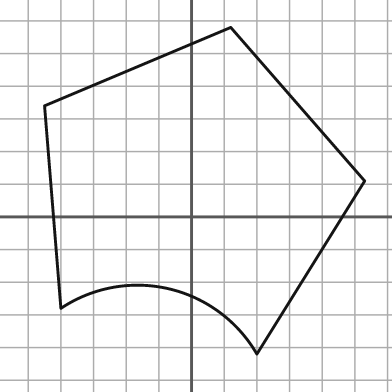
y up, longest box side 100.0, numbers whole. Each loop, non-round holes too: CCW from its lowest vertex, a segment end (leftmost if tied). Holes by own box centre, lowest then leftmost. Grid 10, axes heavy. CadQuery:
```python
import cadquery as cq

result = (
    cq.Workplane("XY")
    .moveTo(20.0, -42.0)
    .lineTo(53.0, 11.0)
    .lineTo(12.0, 58.0)
    .lineTo(-45.0, 34.0)
    .lineTo(-40.0, -28.0)
    .threePointArc((-7.0, -22.0), (20.0, -42.0))
    .close()
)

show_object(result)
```